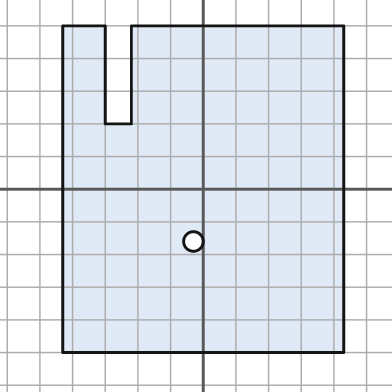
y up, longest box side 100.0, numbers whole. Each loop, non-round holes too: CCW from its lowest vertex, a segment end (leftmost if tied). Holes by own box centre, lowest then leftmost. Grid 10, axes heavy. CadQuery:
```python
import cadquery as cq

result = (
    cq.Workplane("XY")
    .moveTo(-43.0, -50.0)
    .lineTo(43.0, -50.0)
    .lineTo(43.0, 50.0)
    .lineTo(-22.0, 50.0)
    .lineTo(-22.0, 20.0)
    .lineTo(-30.0, 20.0)
    .lineTo(-30.0, 50.0)
    .lineTo(-43.0, 50.0)
    .close()
    .moveTo(-3.0, -16.0)
    .circle(3.0)
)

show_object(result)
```